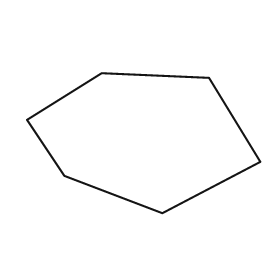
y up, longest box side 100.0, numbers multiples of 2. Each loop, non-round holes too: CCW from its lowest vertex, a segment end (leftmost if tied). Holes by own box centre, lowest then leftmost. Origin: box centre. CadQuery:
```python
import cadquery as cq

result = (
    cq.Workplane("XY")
    .moveTo(8.0, -30.0)
    .lineTo(50.0, -8.0)
    .lineTo(28.0, 28.0)
    .lineTo(-18.0, 30.0)
    .lineTo(-50.0, 10.0)
    .lineTo(-34.0, -14.0)
    .close()
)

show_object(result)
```